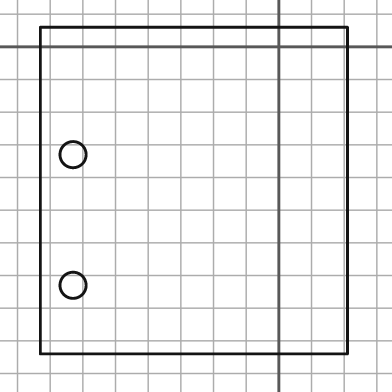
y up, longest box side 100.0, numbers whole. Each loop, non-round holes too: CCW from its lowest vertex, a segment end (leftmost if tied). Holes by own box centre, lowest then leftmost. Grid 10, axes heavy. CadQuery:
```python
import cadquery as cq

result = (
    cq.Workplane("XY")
    .moveTo(-73.0, -94.0)
    .lineTo(21.0, -94.0)
    .lineTo(21.0, 6.0)
    .lineTo(-73.0, 6.0)
    .close()
    .moveTo(-63.0, -73.0)
    .circle(4.0)
    .moveTo(-63.0, -33.0)
    .circle(4.0)
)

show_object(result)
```